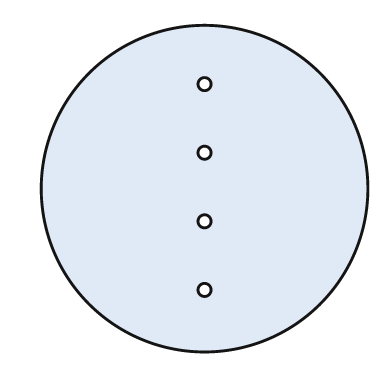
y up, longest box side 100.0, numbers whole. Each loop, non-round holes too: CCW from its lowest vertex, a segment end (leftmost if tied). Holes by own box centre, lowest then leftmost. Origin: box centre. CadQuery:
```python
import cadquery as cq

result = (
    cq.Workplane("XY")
    .moveTo(0.0, 0.0)
    .circle(50.0)
    .moveTo(0.0, -31.0)
    .circle(2.0)
    .moveTo(0.0, -10.0)
    .circle(2.0)
    .moveTo(0.0, 11.0)
    .circle(2.0)
    .moveTo(0.0, 32.0)
    .circle(2.0)
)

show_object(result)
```